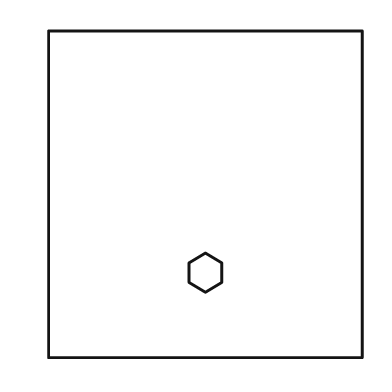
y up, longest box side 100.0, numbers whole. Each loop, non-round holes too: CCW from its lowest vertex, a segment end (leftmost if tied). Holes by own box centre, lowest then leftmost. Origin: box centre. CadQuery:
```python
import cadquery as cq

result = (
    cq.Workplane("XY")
    .moveTo(-48.0, -50.0)
    .lineTo(48.0, -50.0)
    .lineTo(48.0, 50.0)
    .lineTo(-48.0, 50.0)
    .close()
    .moveTo(0.0, -30.0)
    .lineTo(5.0, -27.0)
    .lineTo(5.0, -21.0)
    .lineTo(0.0, -18.0)
    .lineTo(-5.0, -21.0)
    .lineTo(-5.0, -27.0)
    .close()
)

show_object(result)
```